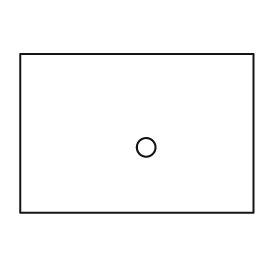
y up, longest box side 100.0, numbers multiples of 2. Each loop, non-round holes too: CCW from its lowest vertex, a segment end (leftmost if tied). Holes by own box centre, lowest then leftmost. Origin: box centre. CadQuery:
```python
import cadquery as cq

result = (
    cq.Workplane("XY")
    .moveTo(-50.0, -34.0)
    .lineTo(50.0, -34.0)
    .lineTo(50.0, 34.0)
    .lineTo(-50.0, 34.0)
    .close()
    .moveTo(4.0, -6.0)
    .circle(4.0)
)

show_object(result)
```